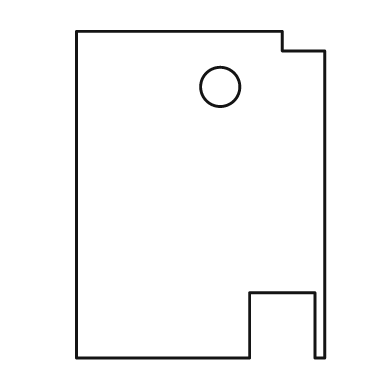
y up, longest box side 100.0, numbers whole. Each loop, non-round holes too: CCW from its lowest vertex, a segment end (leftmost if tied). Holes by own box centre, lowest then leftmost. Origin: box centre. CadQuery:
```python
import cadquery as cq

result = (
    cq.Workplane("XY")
    .moveTo(-38.0, -50.0)
    .lineTo(15.0, -50.0)
    .lineTo(15.0, -30.0)
    .lineTo(35.0, -30.0)
    .lineTo(35.0, -50.0)
    .lineTo(38.0, -50.0)
    .lineTo(38.0, 44.0)
    .lineTo(25.0, 44.0)
    .lineTo(25.0, 50.0)
    .lineTo(-38.0, 50.0)
    .close()
    .moveTo(6.0, 33.0)
    .circle(6.0)
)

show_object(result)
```